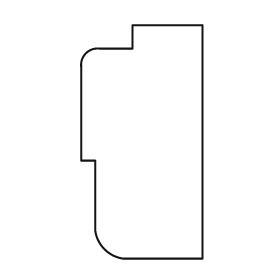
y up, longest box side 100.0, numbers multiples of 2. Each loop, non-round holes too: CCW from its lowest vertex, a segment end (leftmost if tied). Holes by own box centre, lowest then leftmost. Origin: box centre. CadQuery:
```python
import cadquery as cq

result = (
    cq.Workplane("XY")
    .moveTo(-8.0, -50.0)
    .lineTo(26.0, -50.0)
    .lineTo(26.0, 50.0)
    .lineTo(-4.0, 50.0)
    .lineTo(-4.0, 40.0)
    .lineTo(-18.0, 40.0)
    .threePointArc((-24.0, 38.0), (-26.0, 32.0))
    .lineTo(-26.0, -8.0)
    .lineTo(-20.0, -8.0)
    .lineTo(-20.0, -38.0)
    .threePointArc((-16.0, -46.0), (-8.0, -50.0))
    .close()
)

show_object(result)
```